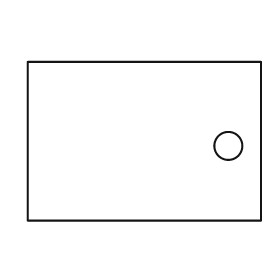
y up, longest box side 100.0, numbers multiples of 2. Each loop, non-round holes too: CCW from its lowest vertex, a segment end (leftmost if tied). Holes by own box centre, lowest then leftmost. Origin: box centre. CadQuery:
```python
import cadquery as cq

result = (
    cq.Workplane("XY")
    .moveTo(-50.0, -34.0)
    .lineTo(50.0, -34.0)
    .lineTo(50.0, 34.0)
    .lineTo(-50.0, 34.0)
    .close()
    .moveTo(36.0, -2.0)
    .circle(6.0)
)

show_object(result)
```